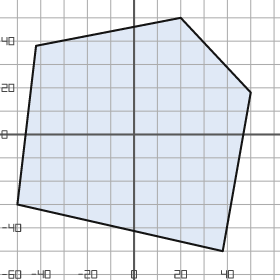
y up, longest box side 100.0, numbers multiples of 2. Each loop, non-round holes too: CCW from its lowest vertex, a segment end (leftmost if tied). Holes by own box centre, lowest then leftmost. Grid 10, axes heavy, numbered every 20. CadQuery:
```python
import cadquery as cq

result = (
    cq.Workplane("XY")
    .moveTo(38.0, -50.0)
    .lineTo(50.0, 18.0)
    .lineTo(20.0, 50.0)
    .lineTo(-42.0, 38.0)
    .lineTo(-50.0, -30.0)
    .close()
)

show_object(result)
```